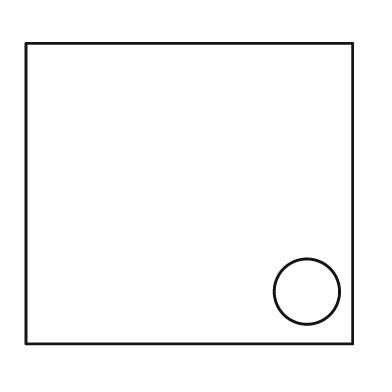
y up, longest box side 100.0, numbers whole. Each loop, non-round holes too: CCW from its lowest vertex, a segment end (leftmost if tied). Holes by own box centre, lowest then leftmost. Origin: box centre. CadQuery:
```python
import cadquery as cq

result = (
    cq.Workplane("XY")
    .moveTo(-50.0, -46.0)
    .lineTo(50.0, -46.0)
    .lineTo(50.0, 46.0)
    .lineTo(-50.0, 46.0)
    .close()
    .moveTo(36.0, -30.0)
    .circle(10.0)
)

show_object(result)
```